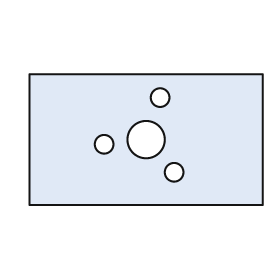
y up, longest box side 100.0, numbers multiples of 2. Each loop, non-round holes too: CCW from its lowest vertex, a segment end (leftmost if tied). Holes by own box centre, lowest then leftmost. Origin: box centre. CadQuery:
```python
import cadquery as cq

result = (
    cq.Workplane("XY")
    .moveTo(-50.0, -28.0)
    .lineTo(50.0, -28.0)
    .lineTo(50.0, 28.0)
    .lineTo(-50.0, 28.0)
    .close()
    .moveTo(12.0, -14.0)
    .circle(4.0)
    .moveTo(-18.0, -2.0)
    .circle(4.0)
    .moveTo(0.0, 0.0)
    .circle(8.0)
    .moveTo(6.0, 18.0)
    .circle(4.0)
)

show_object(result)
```